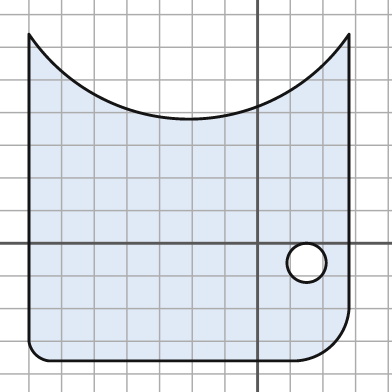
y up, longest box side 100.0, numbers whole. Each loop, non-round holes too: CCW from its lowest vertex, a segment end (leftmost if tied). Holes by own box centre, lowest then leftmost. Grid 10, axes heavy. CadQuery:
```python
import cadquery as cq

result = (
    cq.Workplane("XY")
    .moveTo(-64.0, -36.0)
    .lineTo(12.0, -36.0)
    .threePointArc((23.0, -31.0), (28.0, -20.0))
    .lineTo(28.0, 64.0)
    .threePointArc((-21.0, 38.0), (-70.0, 64.0))
    .lineTo(-70.0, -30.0)
    .threePointArc((-68.0, -34.0), (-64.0, -36.0))
    .close()
    .moveTo(15.0, -6.0)
    .circle(6.0)
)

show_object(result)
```